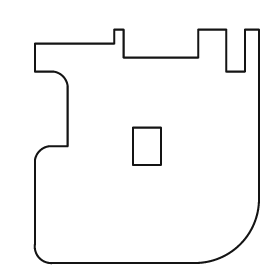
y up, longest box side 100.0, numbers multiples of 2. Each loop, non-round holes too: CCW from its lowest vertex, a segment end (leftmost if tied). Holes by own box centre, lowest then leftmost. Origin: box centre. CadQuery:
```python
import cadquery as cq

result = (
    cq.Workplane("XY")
    .moveTo(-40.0, -50.0)
    .lineTo(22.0, -50.0)
    .threePointArc((40.0, -42.0), (48.0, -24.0))
    .lineTo(48.0, 50.0)
    .lineTo(42.0, 50.0)
    .lineTo(42.0, 32.0)
    .lineTo(34.0, 32.0)
    .lineTo(34.0, 50.0)
    .lineTo(22.0, 50.0)
    .lineTo(22.0, 38.0)
    .lineTo(-10.0, 38.0)
    .lineTo(-10.0, 50.0)
    .lineTo(-14.0, 50.0)
    .lineTo(-14.0, 44.0)
    .lineTo(-48.0, 44.0)
    .lineTo(-48.0, 32.0)
    .lineTo(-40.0, 32.0)
    .threePointArc((-36.0, 30.0), (-34.0, 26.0))
    .lineTo(-34.0, 0.0)
    .lineTo(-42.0, 0.0)
    .threePointArc((-46.0, -2.0), (-48.0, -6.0))
    .lineTo(-48.0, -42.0)
    .threePointArc((-46.0, -48.0), (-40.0, -50.0))
    .close()
    .moveTo(-6.0, -8.0)
    .lineTo(6.0, -8.0)
    .lineTo(6.0, 8.0)
    .lineTo(-6.0, 8.0)
    .close()
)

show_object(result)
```